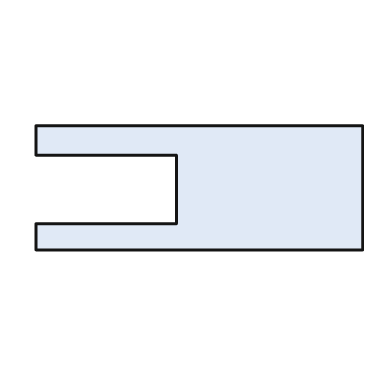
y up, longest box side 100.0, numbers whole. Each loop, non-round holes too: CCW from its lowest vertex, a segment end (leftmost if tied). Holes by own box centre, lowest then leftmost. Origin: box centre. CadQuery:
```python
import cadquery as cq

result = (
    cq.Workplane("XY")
    .moveTo(-50.0, -19.0)
    .lineTo(50.0, -19.0)
    .lineTo(50.0, 19.0)
    .lineTo(-50.0, 19.0)
    .lineTo(-50.0, 10.0)
    .lineTo(-7.0, 10.0)
    .lineTo(-7.0, -11.0)
    .lineTo(-50.0, -11.0)
    .close()
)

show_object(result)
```